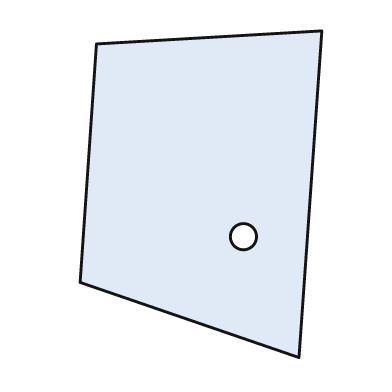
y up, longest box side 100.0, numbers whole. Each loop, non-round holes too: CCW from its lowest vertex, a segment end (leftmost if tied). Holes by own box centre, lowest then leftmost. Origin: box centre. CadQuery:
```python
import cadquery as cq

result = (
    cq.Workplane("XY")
    .moveTo(30.0, -50.0)
    .lineTo(37.0, 50.0)
    .lineTo(-32.0, 46.0)
    .lineTo(-37.0, -27.0)
    .close()
    .moveTo(13.0, -13.0)
    .circle(4.0)
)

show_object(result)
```